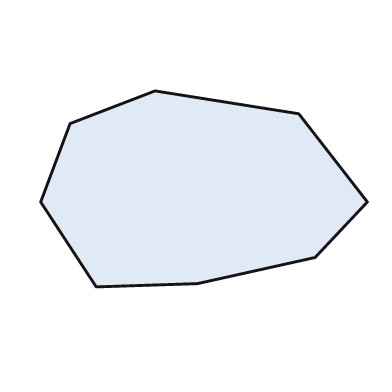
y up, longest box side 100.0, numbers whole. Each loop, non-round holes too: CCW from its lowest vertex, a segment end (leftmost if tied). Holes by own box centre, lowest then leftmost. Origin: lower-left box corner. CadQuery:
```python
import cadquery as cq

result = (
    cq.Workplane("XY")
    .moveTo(17.0, 0.0)
    .lineTo(48.0, 1.0)
    .lineTo(84.0, 9.0)
    .lineTo(100.0, 26.0)
    .lineTo(79.0, 53.0)
    .lineTo(35.0, 60.0)
    .lineTo(9.0, 50.0)
    .lineTo(0.0, 26.0)
    .close()
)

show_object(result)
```